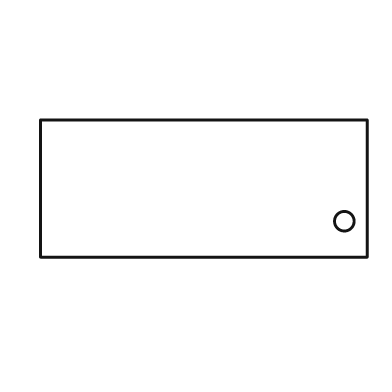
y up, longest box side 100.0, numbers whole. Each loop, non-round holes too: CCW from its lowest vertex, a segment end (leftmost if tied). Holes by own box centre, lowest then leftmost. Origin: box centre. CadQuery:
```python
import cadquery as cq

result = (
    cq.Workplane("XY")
    .moveTo(-50.0, -21.0)
    .lineTo(50.0, -21.0)
    .lineTo(50.0, 21.0)
    .lineTo(-50.0, 21.0)
    .close()
    .moveTo(43.0, -10.0)
    .circle(3.0)
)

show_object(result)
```